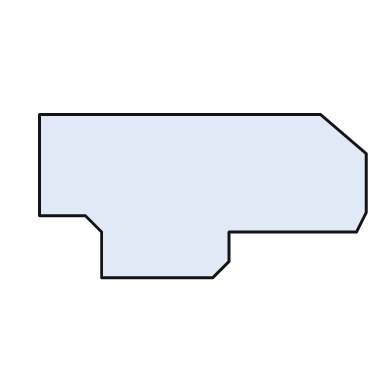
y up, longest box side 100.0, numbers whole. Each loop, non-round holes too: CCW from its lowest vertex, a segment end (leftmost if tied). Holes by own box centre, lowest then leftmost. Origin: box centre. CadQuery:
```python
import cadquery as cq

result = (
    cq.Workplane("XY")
    .moveTo(-31.0, -25.0)
    .lineTo(3.0, -25.0)
    .lineTo(8.0, -20.0)
    .lineTo(8.0, -11.0)
    .lineTo(47.0, -11.0)
    .lineTo(50.0, -5.0)
    .lineTo(50.0, 13.0)
    .lineTo(36.0, 25.0)
    .lineTo(-50.0, 25.0)
    .lineTo(-50.0, -6.0)
    .lineTo(-36.0, -6.0)
    .lineTo(-31.0, -11.0)
    .close()
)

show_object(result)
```